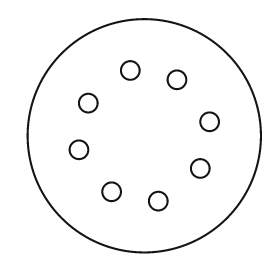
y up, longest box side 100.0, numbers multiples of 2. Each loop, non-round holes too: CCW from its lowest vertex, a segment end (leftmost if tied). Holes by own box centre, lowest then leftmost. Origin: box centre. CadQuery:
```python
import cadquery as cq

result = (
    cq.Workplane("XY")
    .moveTo(0.0, 0.0)
    .circle(50.0)
    .moveTo(6.0, -28.0)
    .circle(4.0)
    .moveTo(-14.0, -24.0)
    .circle(4.0)
    .moveTo(24.0, -14.0)
    .circle(4.0)
    .moveTo(-28.0, -6.0)
    .circle(4.0)
    .moveTo(28.0, 6.0)
    .circle(4.0)
    .moveTo(-24.0, 14.0)
    .circle(4.0)
    .moveTo(14.0, 24.0)
    .circle(4.0)
    .moveTo(-6.0, 28.0)
    .circle(4.0)
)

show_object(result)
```